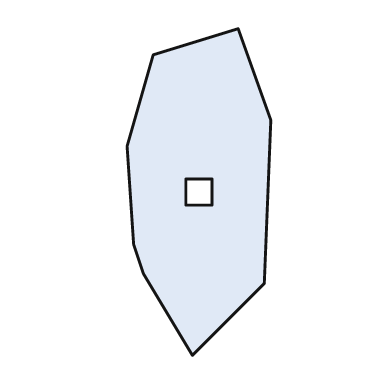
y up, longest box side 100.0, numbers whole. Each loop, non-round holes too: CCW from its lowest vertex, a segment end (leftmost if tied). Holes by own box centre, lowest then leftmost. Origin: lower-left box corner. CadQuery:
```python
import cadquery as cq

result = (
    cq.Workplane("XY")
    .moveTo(20.0, 0.0)
    .lineTo(42.0, 22.0)
    .lineTo(44.0, 72.0)
    .lineTo(34.0, 100.0)
    .lineTo(8.0, 92.0)
    .lineTo(0.0, 64.0)
    .lineTo(2.0, 34.0)
    .lineTo(5.0, 25.0)
    .close()
    .moveTo(18.0, 46.0)
    .lineTo(26.0, 46.0)
    .lineTo(26.0, 54.0)
    .lineTo(18.0, 54.0)
    .close()
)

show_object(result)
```